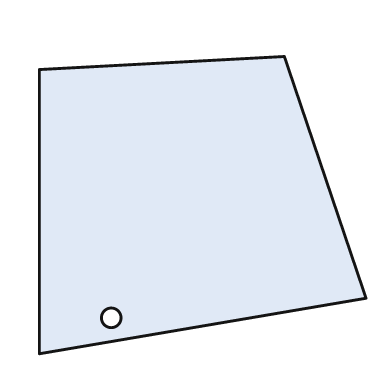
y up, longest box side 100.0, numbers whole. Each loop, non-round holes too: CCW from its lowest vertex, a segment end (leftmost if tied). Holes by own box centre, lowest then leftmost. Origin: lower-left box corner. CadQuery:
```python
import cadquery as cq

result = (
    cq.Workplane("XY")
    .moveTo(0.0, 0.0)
    .lineTo(100.0, 17.0)
    .lineTo(75.0, 91.0)
    .lineTo(0.0, 87.0)
    .close()
    .moveTo(22.0, 11.0)
    .circle(3.0)
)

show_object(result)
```